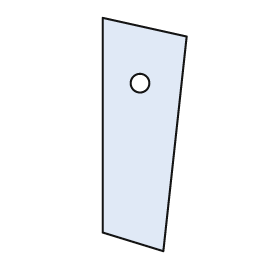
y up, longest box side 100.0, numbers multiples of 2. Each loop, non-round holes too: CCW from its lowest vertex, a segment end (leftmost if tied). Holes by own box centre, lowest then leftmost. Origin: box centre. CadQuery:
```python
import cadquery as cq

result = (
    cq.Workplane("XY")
    .moveTo(8.0, -50.0)
    .lineTo(18.0, 42.0)
    .lineTo(-18.0, 50.0)
    .lineTo(-18.0, -42.0)
    .close()
    .moveTo(-2.0, 22.0)
    .circle(4.0)
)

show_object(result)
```